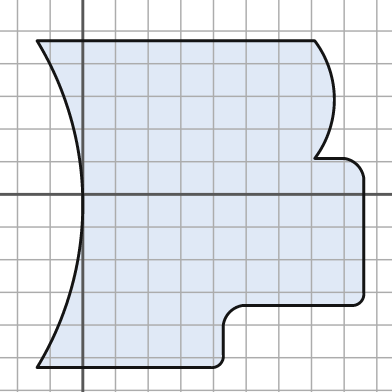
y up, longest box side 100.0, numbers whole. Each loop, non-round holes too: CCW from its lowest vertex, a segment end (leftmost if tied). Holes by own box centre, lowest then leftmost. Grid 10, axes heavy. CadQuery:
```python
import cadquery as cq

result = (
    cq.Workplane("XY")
    .moveTo(-14.0, -53.0)
    .lineTo(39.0, -53.0)
    .threePointArc((42.0, -52.0), (43.0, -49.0))
    .lineTo(43.0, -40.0)
    .threePointArc((45.0, -36.0), (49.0, -34.0))
    .lineTo(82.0, -34.0)
    .threePointArc((85.0, -33.0), (86.0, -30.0))
    .lineTo(86.0, 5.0)
    .threePointArc((84.0, 9.0), (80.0, 11.0))
    .lineTo(71.0, 11.0)
    .threePointArc((77.0, 29.0), (71.0, 47.0))
    .lineTo(-14.0, 47.0)
    .threePointArc((0.0, -3.0), (-14.0, -53.0))
    .close()
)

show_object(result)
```